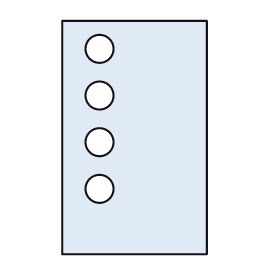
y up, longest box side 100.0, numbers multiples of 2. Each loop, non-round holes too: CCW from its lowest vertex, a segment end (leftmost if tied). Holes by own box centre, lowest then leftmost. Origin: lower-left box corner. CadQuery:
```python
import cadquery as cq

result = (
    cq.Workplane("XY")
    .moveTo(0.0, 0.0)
    .lineTo(62.0, 0.0)
    .lineTo(62.0, 100.0)
    .lineTo(0.0, 100.0)
    .close()
    .moveTo(16.0, 28.0)
    .circle(6.0)
    .moveTo(16.0, 48.0)
    .circle(6.0)
    .moveTo(16.0, 68.0)
    .circle(6.0)
    .moveTo(16.0, 88.0)
    .circle(6.0)
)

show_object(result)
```